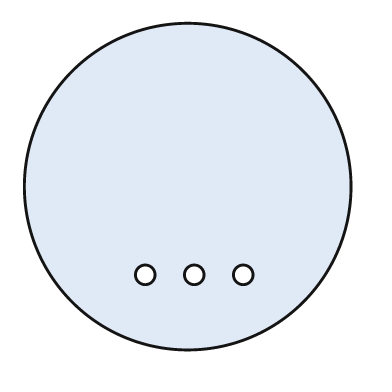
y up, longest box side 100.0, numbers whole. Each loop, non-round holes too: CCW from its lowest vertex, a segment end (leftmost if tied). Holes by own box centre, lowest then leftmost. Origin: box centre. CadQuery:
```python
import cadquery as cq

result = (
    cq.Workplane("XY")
    .moveTo(0.0, 0.0)
    .circle(50.0)
    .moveTo(-13.0, -27.0)
    .circle(3.0)
    .moveTo(2.0, -27.0)
    .circle(3.0)
    .moveTo(17.0, -27.0)
    .circle(3.0)
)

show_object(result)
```